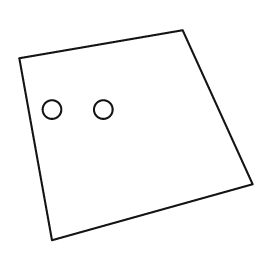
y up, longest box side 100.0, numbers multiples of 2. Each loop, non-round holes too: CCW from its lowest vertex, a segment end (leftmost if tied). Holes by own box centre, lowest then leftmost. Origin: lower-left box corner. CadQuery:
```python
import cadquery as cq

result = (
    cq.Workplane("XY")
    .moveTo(14.0, 0.0)
    .lineTo(100.0, 24.0)
    .lineTo(70.0, 90.0)
    .lineTo(0.0, 78.0)
    .close()
    .moveTo(14.0, 56.0)
    .circle(4.0)
    .moveTo(36.0, 56.0)
    .circle(4.0)
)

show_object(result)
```